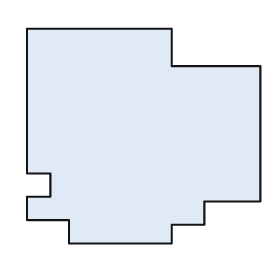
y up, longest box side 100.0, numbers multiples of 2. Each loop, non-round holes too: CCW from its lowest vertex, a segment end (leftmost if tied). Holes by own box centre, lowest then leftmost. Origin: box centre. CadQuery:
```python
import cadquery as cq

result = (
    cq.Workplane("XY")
    .moveTo(-32.0, -46.0)
    .lineTo(12.0, -46.0)
    .lineTo(12.0, -38.0)
    .lineTo(26.0, -38.0)
    .lineTo(26.0, -28.0)
    .lineTo(50.0, -28.0)
    .lineTo(50.0, 30.0)
    .lineTo(12.0, 30.0)
    .lineTo(12.0, 46.0)
    .lineTo(-50.0, 46.0)
    .lineTo(-50.0, -16.0)
    .lineTo(-40.0, -16.0)
    .lineTo(-40.0, -26.0)
    .lineTo(-50.0, -26.0)
    .lineTo(-50.0, -36.0)
    .lineTo(-32.0, -36.0)
    .close()
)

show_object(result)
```